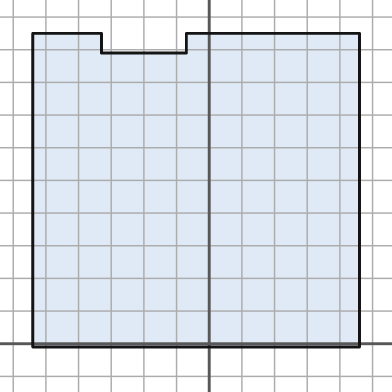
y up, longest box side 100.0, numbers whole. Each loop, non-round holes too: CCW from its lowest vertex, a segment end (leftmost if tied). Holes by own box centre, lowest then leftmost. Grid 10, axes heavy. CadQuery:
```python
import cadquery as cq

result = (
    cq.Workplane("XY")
    .moveTo(-54.0, -1.0)
    .lineTo(46.0, -1.0)
    .lineTo(46.0, 95.0)
    .lineTo(-7.0, 95.0)
    .lineTo(-7.0, 89.0)
    .lineTo(-33.0, 89.0)
    .lineTo(-33.0, 95.0)
    .lineTo(-54.0, 95.0)
    .close()
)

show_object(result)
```